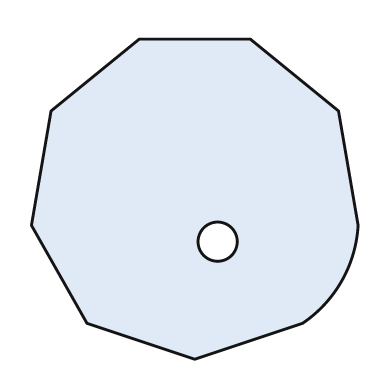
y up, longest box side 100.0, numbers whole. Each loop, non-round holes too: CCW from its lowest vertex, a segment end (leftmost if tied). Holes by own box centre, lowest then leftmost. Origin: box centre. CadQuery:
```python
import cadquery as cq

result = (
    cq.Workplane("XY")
    .moveTo(0.0, -49.0)
    .lineTo(33.0, -38.0)
    .threePointArc((45.0, -25.0), (50.0, -8.0))
    .lineTo(44.0, 27.0)
    .lineTo(17.0, 49.0)
    .lineTo(-17.0, 49.0)
    .lineTo(-44.0, 27.0)
    .lineTo(-50.0, -8.0)
    .lineTo(-33.0, -38.0)
    .close()
    .moveTo(7.0, -13.0)
    .circle(6.0)
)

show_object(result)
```